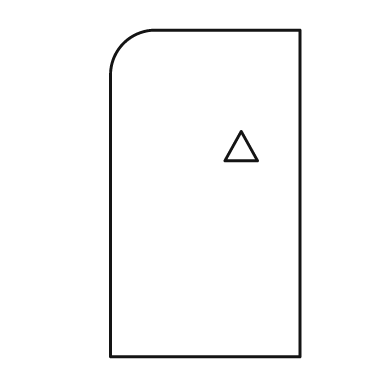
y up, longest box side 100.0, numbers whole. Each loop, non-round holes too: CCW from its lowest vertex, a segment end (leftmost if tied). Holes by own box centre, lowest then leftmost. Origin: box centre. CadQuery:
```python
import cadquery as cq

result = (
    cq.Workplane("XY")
    .moveTo(-29.0, -50.0)
    .lineTo(29.0, -50.0)
    .lineTo(29.0, 50.0)
    .lineTo(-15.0, 50.0)
    .threePointArc((-25.0, 46.0), (-29.0, 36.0))
    .close()
    .moveTo(6.0, 10.0)
    .lineTo(16.0, 10.0)
    .lineTo(11.0, 19.0)
    .close()
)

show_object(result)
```